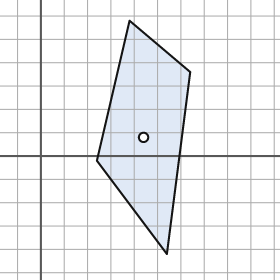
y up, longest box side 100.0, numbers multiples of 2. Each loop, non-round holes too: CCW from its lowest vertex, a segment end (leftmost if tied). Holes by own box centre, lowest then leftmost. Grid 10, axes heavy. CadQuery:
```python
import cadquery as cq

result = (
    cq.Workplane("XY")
    .moveTo(54.0, -42.0)
    .lineTo(64.0, 36.0)
    .lineTo(38.0, 58.0)
    .lineTo(24.0, -2.0)
    .close()
    .moveTo(44.0, 8.0)
    .circle(2.0)
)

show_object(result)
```